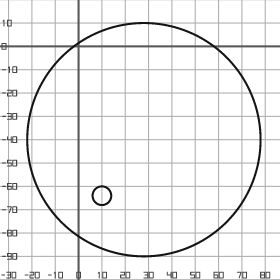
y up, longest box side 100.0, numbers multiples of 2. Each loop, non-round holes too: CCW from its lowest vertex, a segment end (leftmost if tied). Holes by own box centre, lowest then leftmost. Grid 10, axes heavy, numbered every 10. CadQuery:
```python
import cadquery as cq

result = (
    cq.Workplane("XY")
    .moveTo(28.0, -40.0)
    .circle(50.0)
    .moveTo(10.0, -64.0)
    .circle(4.0)
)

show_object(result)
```